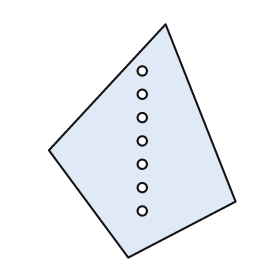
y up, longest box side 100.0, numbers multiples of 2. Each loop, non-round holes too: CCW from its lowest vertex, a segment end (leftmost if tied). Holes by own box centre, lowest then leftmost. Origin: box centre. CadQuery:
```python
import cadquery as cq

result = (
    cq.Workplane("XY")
    .moveTo(-6.0, -50.0)
    .lineTo(40.0, -26.0)
    .lineTo(10.0, 50.0)
    .lineTo(-40.0, -4.0)
    .close()
    .moveTo(0.0, -30.0)
    .circle(2.0)
    .moveTo(0.0, -20.0)
    .circle(2.0)
    .moveTo(0.0, -10.0)
    .circle(2.0)
    .moveTo(0.0, 0.0)
    .circle(2.0)
    .moveTo(0.0, 10.0)
    .circle(2.0)
    .moveTo(0.0, 20.0)
    .circle(2.0)
    .moveTo(0.0, 30.0)
    .circle(2.0)
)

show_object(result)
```